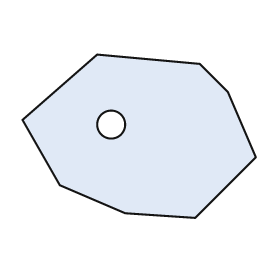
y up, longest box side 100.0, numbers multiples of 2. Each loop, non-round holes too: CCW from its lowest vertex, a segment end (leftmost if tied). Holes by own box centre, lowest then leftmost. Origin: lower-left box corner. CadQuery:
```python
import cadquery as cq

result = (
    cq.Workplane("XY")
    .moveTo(74.0, 0.0)
    .lineTo(100.0, 26.0)
    .lineTo(88.0, 54.0)
    .lineTo(76.0, 66.0)
    .lineTo(32.0, 70.0)
    .lineTo(0.0, 42.0)
    .lineTo(16.0, 14.0)
    .lineTo(44.0, 2.0)
    .close()
    .moveTo(38.0, 40.0)
    .circle(6.0)
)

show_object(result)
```